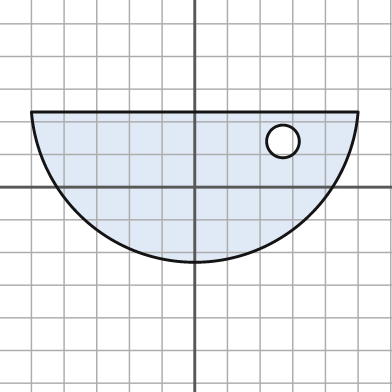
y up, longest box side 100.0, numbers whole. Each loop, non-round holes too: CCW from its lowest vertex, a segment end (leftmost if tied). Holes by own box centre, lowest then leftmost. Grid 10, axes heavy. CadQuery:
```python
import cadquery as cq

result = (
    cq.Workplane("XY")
    .moveTo(-50.0, 23.0)
    .threePointArc((0.0, -23.0), (50.0, 23.0))
    .close()
    .moveTo(27.0, 14.0)
    .circle(5.0)
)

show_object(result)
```